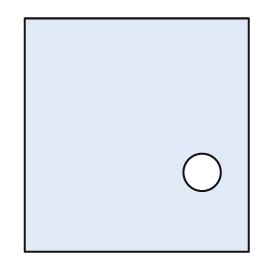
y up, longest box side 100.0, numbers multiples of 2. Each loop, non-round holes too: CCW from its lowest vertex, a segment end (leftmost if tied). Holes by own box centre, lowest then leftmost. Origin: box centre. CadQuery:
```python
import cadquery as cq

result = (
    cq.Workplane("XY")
    .moveTo(-48.0, -50.0)
    .lineTo(48.0, -50.0)
    .lineTo(48.0, 50.0)
    .lineTo(-48.0, 50.0)
    .close()
    .moveTo(28.0, -16.0)
    .circle(8.0)
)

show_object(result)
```